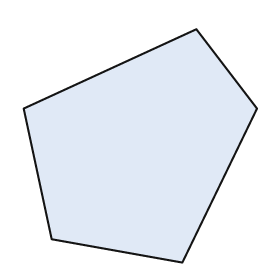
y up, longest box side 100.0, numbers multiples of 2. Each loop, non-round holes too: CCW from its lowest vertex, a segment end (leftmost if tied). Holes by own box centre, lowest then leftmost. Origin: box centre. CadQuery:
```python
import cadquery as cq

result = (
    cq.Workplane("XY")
    .moveTo(18.0, -50.0)
    .lineTo(50.0, 16.0)
    .lineTo(24.0, 50.0)
    .lineTo(-50.0, 16.0)
    .lineTo(-38.0, -40.0)
    .close()
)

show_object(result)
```